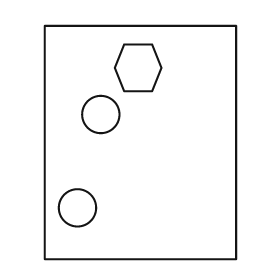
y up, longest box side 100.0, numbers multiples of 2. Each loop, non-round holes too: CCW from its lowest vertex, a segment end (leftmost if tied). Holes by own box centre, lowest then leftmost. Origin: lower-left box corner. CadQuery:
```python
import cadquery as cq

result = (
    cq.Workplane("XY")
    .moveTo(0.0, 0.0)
    .lineTo(82.0, 0.0)
    .lineTo(82.0, 100.0)
    .lineTo(0.0, 100.0)
    .close()
    .moveTo(14.0, 22.0)
    .circle(8.0)
    .moveTo(24.0, 62.0)
    .circle(8.0)
    .moveTo(34.0, 72.0)
    .lineTo(46.0, 72.0)
    .lineTo(50.0, 82.0)
    .lineTo(46.0, 92.0)
    .lineTo(34.0, 92.0)
    .lineTo(30.0, 82.0)
    .close()
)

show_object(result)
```